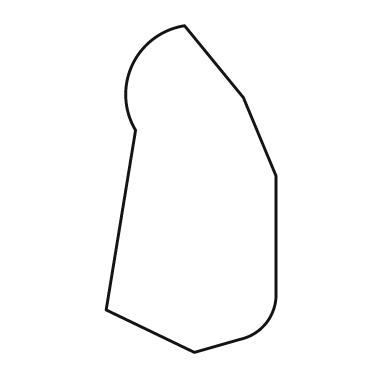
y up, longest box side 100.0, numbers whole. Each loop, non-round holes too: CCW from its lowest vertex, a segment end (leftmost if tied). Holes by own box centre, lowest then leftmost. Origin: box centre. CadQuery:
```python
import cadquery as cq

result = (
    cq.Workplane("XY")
    .moveTo(1.0, -50.0)
    .lineTo(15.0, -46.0)
    .threePointArc((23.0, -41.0), (26.0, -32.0))
    .lineTo(26.0, 4.0)
    .lineTo(16.0, 28.0)
    .lineTo(-2.0, 50.0)
    .threePointArc((-18.0, 38.0), (-17.0, 18.0))
    .lineTo(-26.0, -37.0)
    .close()
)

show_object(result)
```